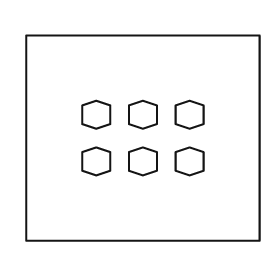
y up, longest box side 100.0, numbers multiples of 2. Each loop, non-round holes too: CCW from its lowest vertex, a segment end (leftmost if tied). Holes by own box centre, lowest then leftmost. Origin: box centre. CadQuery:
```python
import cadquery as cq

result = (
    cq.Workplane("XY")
    .moveTo(-50.0, -44.0)
    .lineTo(50.0, -44.0)
    .lineTo(50.0, 44.0)
    .lineTo(-50.0, 44.0)
    .close()
    .moveTo(-20.0, -16.0)
    .lineTo(-14.0, -14.0)
    .lineTo(-14.0, -6.0)
    .lineTo(-20.0, -4.0)
    .lineTo(-26.0, -6.0)
    .lineTo(-26.0, -14.0)
    .close()
    .moveTo(0.0, -16.0)
    .lineTo(6.0, -14.0)
    .lineTo(6.0, -6.0)
    .lineTo(0.0, -4.0)
    .lineTo(-6.0, -6.0)
    .lineTo(-6.0, -14.0)
    .close()
    .moveTo(20.0, -16.0)
    .lineTo(26.0, -14.0)
    .lineTo(26.0, -6.0)
    .lineTo(20.0, -4.0)
    .lineTo(14.0, -6.0)
    .lineTo(14.0, -14.0)
    .close()
    .moveTo(-20.0, 4.0)
    .lineTo(-14.0, 6.0)
    .lineTo(-14.0, 14.0)
    .lineTo(-20.0, 16.0)
    .lineTo(-26.0, 14.0)
    .lineTo(-26.0, 6.0)
    .close()
    .moveTo(0.0, 4.0)
    .lineTo(6.0, 6.0)
    .lineTo(6.0, 14.0)
    .lineTo(0.0, 16.0)
    .lineTo(-6.0, 14.0)
    .lineTo(-6.0, 6.0)
    .close()
    .moveTo(20.0, 4.0)
    .lineTo(26.0, 6.0)
    .lineTo(26.0, 14.0)
    .lineTo(20.0, 16.0)
    .lineTo(14.0, 14.0)
    .lineTo(14.0, 6.0)
    .close()
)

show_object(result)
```